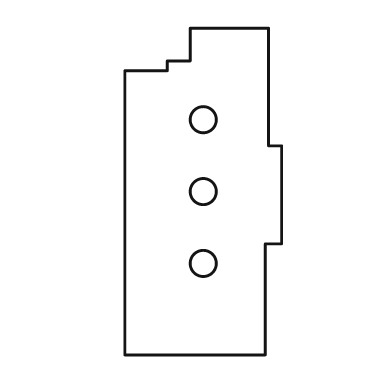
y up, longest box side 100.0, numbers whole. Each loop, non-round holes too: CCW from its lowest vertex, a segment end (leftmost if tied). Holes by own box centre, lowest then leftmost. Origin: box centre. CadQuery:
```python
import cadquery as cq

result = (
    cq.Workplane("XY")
    .moveTo(-24.0, -50.0)
    .lineTo(19.0, -50.0)
    .lineTo(19.0, -16.0)
    .lineTo(24.0, -16.0)
    .lineTo(24.0, 14.0)
    .lineTo(20.0, 14.0)
    .lineTo(20.0, 50.0)
    .lineTo(-4.0, 50.0)
    .lineTo(-4.0, 40.0)
    .lineTo(-11.0, 40.0)
    .lineTo(-11.0, 37.0)
    .lineTo(-24.0, 37.0)
    .close()
    .moveTo(0.0, -22.0)
    .circle(4.0)
    .moveTo(0.0, 0.0)
    .circle(4.0)
    .moveTo(0.0, 22.0)
    .circle(4.0)
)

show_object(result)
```